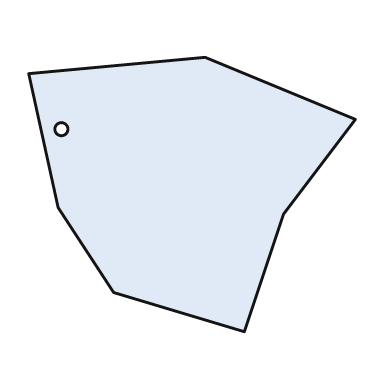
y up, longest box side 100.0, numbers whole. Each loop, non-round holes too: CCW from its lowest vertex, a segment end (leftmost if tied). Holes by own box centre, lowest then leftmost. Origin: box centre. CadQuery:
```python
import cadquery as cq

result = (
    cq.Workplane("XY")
    .moveTo(16.0, -42.0)
    .lineTo(28.0, -6.0)
    .lineTo(50.0, 23.0)
    .lineTo(4.0, 42.0)
    .lineTo(-50.0, 37.0)
    .lineTo(-41.0, -4.0)
    .lineTo(-24.0, -30.0)
    .close()
    .moveTo(-40.0, 20.0)
    .circle(2.0)
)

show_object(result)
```